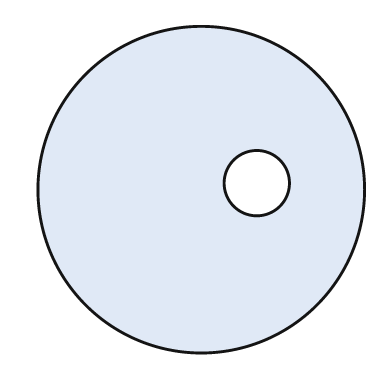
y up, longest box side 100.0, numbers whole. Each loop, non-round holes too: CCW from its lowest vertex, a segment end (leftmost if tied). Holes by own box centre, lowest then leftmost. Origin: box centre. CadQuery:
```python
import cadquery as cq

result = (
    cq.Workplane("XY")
    .moveTo(0.0, 0.0)
    .circle(50.0)
    .moveTo(17.0, 2.0)
    .circle(10.0)
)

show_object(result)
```